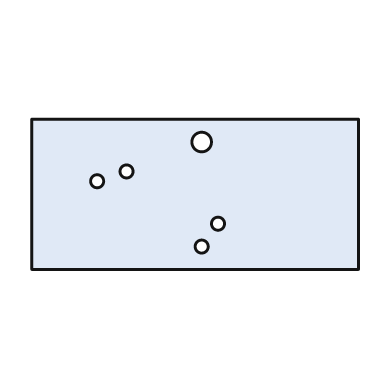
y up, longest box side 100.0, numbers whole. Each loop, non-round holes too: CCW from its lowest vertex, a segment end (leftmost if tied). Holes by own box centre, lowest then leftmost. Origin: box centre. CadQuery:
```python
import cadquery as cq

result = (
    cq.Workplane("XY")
    .moveTo(-50.0, -23.0)
    .lineTo(50.0, -23.0)
    .lineTo(50.0, 23.0)
    .lineTo(-50.0, 23.0)
    .close()
    .moveTo(2.0, -16.0)
    .circle(2.0)
    .moveTo(7.0, -9.0)
    .circle(2.0)
    .moveTo(-30.0, 4.0)
    .circle(2.0)
    .moveTo(-21.0, 7.0)
    .circle(2.0)
    .moveTo(2.0, 16.0)
    .circle(3.0)
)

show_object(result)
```